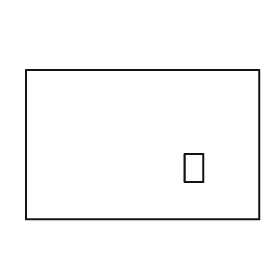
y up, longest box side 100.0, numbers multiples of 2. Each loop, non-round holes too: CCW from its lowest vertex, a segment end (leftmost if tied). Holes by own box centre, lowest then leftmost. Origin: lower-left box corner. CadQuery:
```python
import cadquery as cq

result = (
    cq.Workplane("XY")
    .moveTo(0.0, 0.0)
    .lineTo(100.0, 0.0)
    .lineTo(100.0, 64.0)
    .lineTo(0.0, 64.0)
    .close()
    .moveTo(68.0, 16.0)
    .lineTo(76.0, 16.0)
    .lineTo(76.0, 28.0)
    .lineTo(68.0, 28.0)
    .close()
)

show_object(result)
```